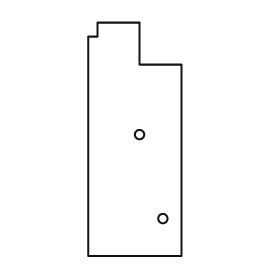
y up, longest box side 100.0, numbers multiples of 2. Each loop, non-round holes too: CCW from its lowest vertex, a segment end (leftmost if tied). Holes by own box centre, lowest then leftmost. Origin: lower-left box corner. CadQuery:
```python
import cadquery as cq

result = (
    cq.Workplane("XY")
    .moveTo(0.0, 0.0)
    .lineTo(40.0, 0.0)
    .lineTo(40.0, 82.0)
    .lineTo(22.0, 82.0)
    .lineTo(22.0, 100.0)
    .lineTo(4.0, 100.0)
    .lineTo(4.0, 94.0)
    .lineTo(0.0, 94.0)
    .close()
    .moveTo(32.0, 16.0)
    .circle(2.0)
    .moveTo(22.0, 52.0)
    .circle(2.0)
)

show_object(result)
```